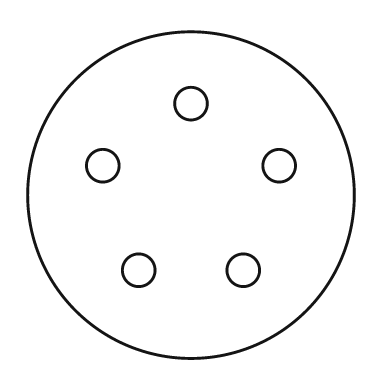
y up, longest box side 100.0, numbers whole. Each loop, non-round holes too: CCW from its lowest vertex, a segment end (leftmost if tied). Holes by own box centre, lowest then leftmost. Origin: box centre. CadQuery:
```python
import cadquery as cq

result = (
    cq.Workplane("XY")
    .moveTo(0.0, 0.0)
    .circle(50.0)
    .moveTo(-16.0, -23.0)
    .circle(5.0)
    .moveTo(16.0, -23.0)
    .circle(5.0)
    .moveTo(-27.0, 9.0)
    .circle(5.0)
    .moveTo(27.0, 9.0)
    .circle(5.0)
    .moveTo(0.0, 28.0)
    .circle(5.0)
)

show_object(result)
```